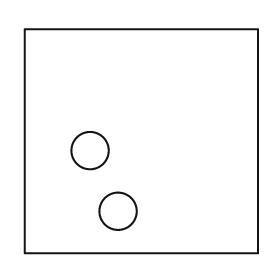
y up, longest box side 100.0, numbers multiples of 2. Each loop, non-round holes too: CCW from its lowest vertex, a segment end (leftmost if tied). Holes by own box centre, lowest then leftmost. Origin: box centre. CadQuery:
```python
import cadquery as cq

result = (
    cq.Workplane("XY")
    .moveTo(-50.0, -48.0)
    .lineTo(50.0, -48.0)
    .lineTo(50.0, 48.0)
    .lineTo(-50.0, 48.0)
    .close()
    .moveTo(-10.0, -30.0)
    .circle(8.0)
    .moveTo(-22.0, -4.0)
    .circle(8.0)
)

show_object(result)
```